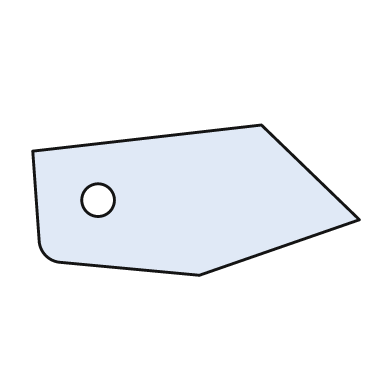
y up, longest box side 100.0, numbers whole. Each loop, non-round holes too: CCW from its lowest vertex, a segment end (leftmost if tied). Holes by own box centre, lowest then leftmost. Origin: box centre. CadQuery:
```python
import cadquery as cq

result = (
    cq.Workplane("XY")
    .moveTo(1.0, -23.0)
    .lineTo(50.0, -6.0)
    .lineTo(20.0, 23.0)
    .lineTo(-50.0, 15.0)
    .lineTo(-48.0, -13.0)
    .threePointArc((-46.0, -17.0), (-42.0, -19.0))
    .close()
    .moveTo(-30.0, 0.0)
    .circle(5.0)
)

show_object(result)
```